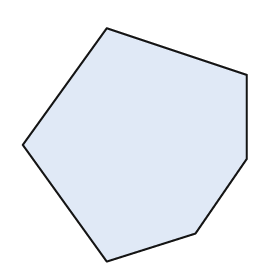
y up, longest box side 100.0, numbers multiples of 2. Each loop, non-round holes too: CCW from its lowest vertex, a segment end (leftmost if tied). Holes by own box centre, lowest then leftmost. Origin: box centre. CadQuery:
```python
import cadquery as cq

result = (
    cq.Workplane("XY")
    .moveTo(-12.0, -50.0)
    .lineTo(26.0, -38.0)
    .lineTo(48.0, -6.0)
    .lineTo(48.0, 30.0)
    .lineTo(-12.0, 50.0)
    .lineTo(-48.0, 0.0)
    .close()
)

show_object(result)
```